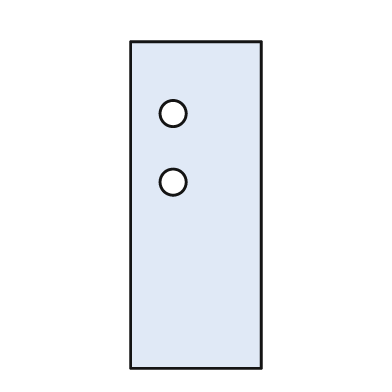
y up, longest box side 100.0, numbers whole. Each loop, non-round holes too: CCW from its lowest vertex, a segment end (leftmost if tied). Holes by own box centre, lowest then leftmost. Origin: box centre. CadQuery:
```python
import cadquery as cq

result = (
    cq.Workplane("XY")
    .moveTo(-20.0, -50.0)
    .lineTo(20.0, -50.0)
    .lineTo(20.0, 50.0)
    .lineTo(-20.0, 50.0)
    .close()
    .moveTo(-7.0, 7.0)
    .circle(4.0)
    .moveTo(-7.0, 28.0)
    .circle(4.0)
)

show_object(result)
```